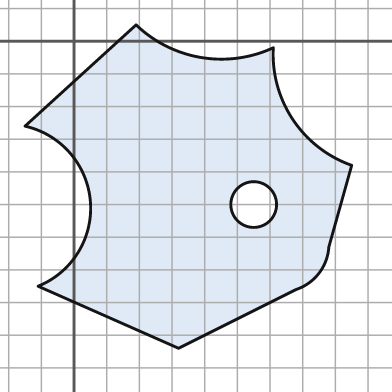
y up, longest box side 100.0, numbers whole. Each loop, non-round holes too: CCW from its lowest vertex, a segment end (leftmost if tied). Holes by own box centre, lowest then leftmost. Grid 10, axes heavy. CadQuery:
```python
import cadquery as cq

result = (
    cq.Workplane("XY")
    .moveTo(32.0, -94.0)
    .lineTo(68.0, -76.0)
    .threePointArc((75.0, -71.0), (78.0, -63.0))
    .lineTo(85.0, -38.0)
    .threePointArc((67.0, -24.0), (61.0, -2.0))
    .threePointArc((39.0, -5.0), (19.0, 5.0))
    .lineTo(-15.0, -26.0)
    .threePointArc((5.0, -49.0), (-11.0, -75.0))
    .close()
    .moveTo(55.0, -50.0)
    .circle(7.0)
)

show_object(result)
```